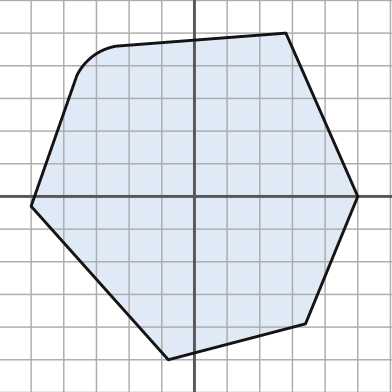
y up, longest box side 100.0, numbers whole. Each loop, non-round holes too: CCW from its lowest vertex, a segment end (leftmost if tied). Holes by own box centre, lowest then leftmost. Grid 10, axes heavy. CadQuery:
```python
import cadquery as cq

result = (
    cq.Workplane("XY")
    .moveTo(-8.0, -50.0)
    .lineTo(34.0, -39.0)
    .lineTo(50.0, 0.0)
    .lineTo(28.0, 50.0)
    .lineTo(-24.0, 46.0)
    .threePointArc((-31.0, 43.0), (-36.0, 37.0))
    .lineTo(-50.0, -3.0)
    .close()
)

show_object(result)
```